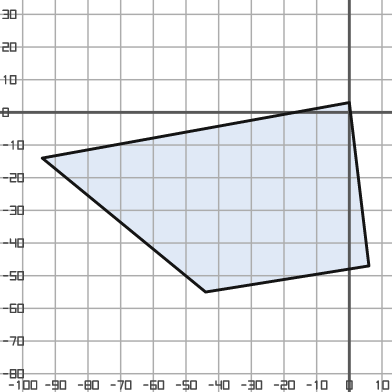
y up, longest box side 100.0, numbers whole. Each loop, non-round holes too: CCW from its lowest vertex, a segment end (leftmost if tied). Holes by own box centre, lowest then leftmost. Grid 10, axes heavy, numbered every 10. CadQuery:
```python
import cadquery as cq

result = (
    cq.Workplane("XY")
    .moveTo(-44.0, -55.0)
    .lineTo(6.0, -47.0)
    .lineTo(0.0, 3.0)
    .lineTo(-94.0, -14.0)
    .close()
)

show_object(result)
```